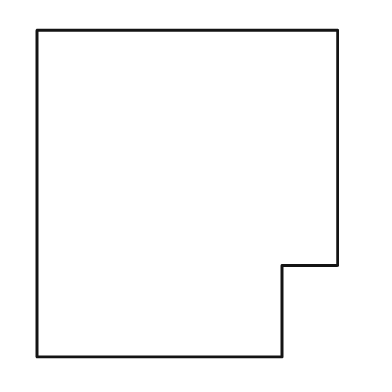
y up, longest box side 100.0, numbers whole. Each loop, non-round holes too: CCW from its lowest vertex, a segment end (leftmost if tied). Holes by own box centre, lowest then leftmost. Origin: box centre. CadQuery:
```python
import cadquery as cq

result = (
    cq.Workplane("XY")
    .moveTo(-46.0, -50.0)
    .lineTo(29.0, -50.0)
    .lineTo(29.0, -22.0)
    .lineTo(46.0, -22.0)
    .lineTo(46.0, 50.0)
    .lineTo(-46.0, 50.0)
    .close()
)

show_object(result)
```